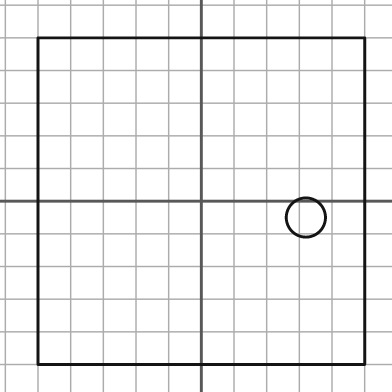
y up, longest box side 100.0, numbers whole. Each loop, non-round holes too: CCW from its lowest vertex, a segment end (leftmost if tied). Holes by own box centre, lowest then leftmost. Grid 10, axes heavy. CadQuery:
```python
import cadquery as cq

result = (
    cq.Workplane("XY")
    .moveTo(-50.0, -50.0)
    .lineTo(50.0, -50.0)
    .lineTo(50.0, 50.0)
    .lineTo(-50.0, 50.0)
    .close()
    .moveTo(32.0, -5.0)
    .circle(6.0)
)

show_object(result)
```